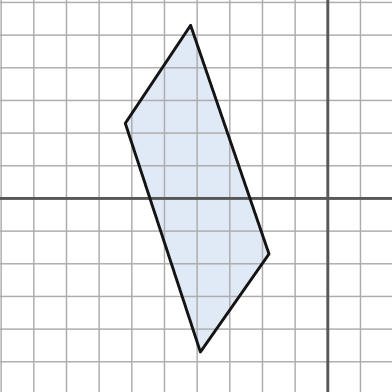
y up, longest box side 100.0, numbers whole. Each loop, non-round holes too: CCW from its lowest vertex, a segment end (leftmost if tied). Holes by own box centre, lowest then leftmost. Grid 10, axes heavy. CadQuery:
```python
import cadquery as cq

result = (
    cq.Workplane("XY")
    .moveTo(-39.0, -47.0)
    .lineTo(-18.0, -17.0)
    .lineTo(-42.0, 53.0)
    .lineTo(-62.0, 23.0)
    .close()
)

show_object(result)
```